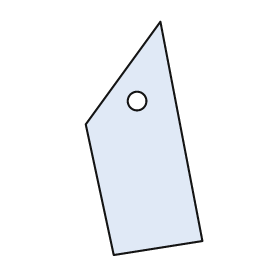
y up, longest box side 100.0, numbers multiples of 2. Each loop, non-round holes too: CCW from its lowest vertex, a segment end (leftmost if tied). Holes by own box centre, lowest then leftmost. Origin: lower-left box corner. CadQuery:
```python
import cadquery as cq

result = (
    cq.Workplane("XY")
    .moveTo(12.0, 0.0)
    .lineTo(50.0, 6.0)
    .lineTo(32.0, 100.0)
    .lineTo(0.0, 56.0)
    .close()
    .moveTo(22.0, 66.0)
    .circle(4.0)
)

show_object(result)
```